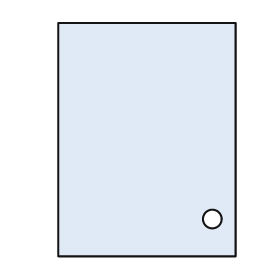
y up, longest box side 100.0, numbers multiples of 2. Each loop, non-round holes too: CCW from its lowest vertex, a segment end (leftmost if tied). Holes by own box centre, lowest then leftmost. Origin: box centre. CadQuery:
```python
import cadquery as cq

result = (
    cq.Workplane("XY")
    .moveTo(-38.0, -50.0)
    .lineTo(38.0, -50.0)
    .lineTo(38.0, 50.0)
    .lineTo(-38.0, 50.0)
    .close()
    .moveTo(28.0, -34.0)
    .circle(4.0)
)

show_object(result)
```